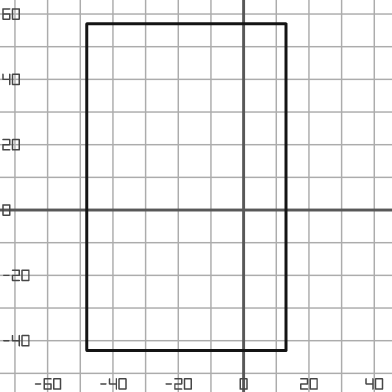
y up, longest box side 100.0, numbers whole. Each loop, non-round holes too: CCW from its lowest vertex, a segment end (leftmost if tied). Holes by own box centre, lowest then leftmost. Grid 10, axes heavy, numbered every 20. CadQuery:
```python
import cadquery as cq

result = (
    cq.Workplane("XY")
    .moveTo(-48.0, -43.0)
    .lineTo(13.0, -43.0)
    .lineTo(13.0, 57.0)
    .lineTo(-48.0, 57.0)
    .close()
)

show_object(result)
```